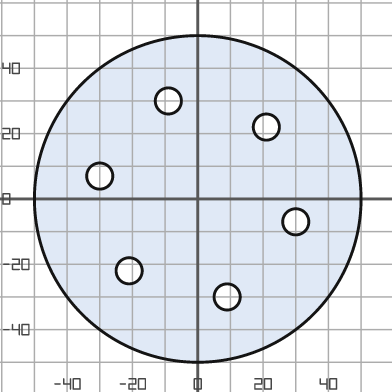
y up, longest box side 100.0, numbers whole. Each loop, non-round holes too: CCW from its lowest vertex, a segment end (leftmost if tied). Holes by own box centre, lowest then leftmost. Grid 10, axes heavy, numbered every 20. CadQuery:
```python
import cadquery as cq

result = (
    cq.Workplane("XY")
    .moveTo(0.0, 0.0)
    .circle(50.0)
    .moveTo(9.0, -30.0)
    .circle(4.0)
    .moveTo(-21.0, -22.0)
    .circle(4.0)
    .moveTo(30.0, -7.0)
    .circle(4.0)
    .moveTo(-30.0, 7.0)
    .circle(4.0)
    .moveTo(21.0, 22.0)
    .circle(4.0)
    .moveTo(-9.0, 30.0)
    .circle(4.0)
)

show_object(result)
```